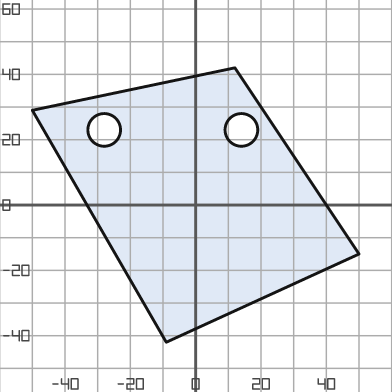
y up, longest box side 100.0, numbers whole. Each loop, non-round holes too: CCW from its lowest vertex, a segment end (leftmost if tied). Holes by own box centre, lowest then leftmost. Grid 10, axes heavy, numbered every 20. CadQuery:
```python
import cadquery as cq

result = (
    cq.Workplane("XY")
    .moveTo(-9.0, -42.0)
    .lineTo(50.0, -15.0)
    .lineTo(12.0, 42.0)
    .lineTo(-50.0, 29.0)
    .close()
    .moveTo(-28.0, 23.0)
    .circle(5.0)
    .moveTo(14.0, 23.0)
    .circle(5.0)
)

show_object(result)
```